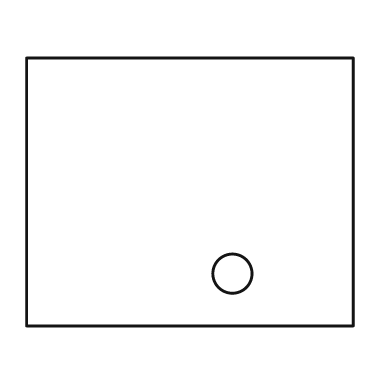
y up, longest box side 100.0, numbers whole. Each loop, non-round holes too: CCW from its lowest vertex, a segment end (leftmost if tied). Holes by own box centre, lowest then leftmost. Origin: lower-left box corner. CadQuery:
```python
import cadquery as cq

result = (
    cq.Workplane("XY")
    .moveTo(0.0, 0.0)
    .lineTo(100.0, 0.0)
    .lineTo(100.0, 82.0)
    .lineTo(0.0, 82.0)
    .close()
    .moveTo(63.0, 16.0)
    .circle(6.0)
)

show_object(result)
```